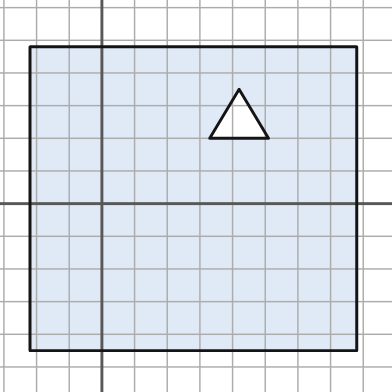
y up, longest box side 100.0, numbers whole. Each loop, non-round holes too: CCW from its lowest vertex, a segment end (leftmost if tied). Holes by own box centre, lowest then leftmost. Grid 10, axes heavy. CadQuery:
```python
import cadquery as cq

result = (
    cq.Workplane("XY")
    .moveTo(-22.0, -45.0)
    .lineTo(78.0, -45.0)
    .lineTo(78.0, 48.0)
    .lineTo(-22.0, 48.0)
    .close()
    .moveTo(33.0, 20.0)
    .lineTo(51.0, 20.0)
    .lineTo(42.0, 35.0)
    .close()
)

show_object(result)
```